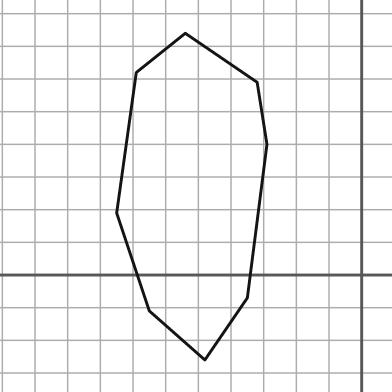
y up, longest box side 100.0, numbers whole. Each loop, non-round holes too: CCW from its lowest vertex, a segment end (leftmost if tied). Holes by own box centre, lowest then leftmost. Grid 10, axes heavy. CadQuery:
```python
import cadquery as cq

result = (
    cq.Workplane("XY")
    .moveTo(-48.0, -26.0)
    .lineTo(-35.0, -7.0)
    .lineTo(-29.0, 40.0)
    .lineTo(-32.0, 59.0)
    .lineTo(-54.0, 74.0)
    .lineTo(-69.0, 62.0)
    .lineTo(-75.0, 19.0)
    .lineTo(-65.0, -11.0)
    .close()
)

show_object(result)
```